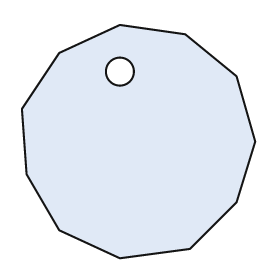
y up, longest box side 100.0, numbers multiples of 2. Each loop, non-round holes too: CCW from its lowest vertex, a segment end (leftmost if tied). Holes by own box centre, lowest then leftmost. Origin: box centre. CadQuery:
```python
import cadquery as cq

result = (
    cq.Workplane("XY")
    .moveTo(-8.0, -50.0)
    .lineTo(22.0, -46.0)
    .lineTo(42.0, -26.0)
    .lineTo(50.0, 0.0)
    .lineTo(42.0, 28.0)
    .lineTo(20.0, 46.0)
    .lineTo(-8.0, 50.0)
    .lineTo(-34.0, 38.0)
    .lineTo(-50.0, 14.0)
    .lineTo(-48.0, -14.0)
    .lineTo(-34.0, -38.0)
    .close()
    .moveTo(-8.0, 30.0)
    .circle(6.0)
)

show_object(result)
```